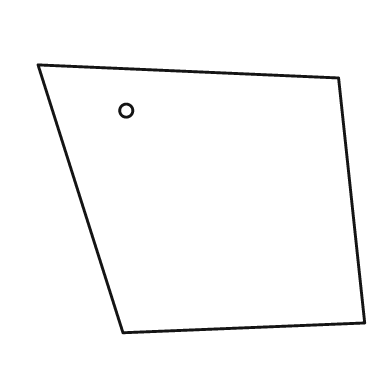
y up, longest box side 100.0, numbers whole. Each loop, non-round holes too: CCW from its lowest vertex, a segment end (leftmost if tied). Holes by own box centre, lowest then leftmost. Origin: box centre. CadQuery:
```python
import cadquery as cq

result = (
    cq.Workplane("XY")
    .moveTo(-24.0, -41.0)
    .lineTo(50.0, -38.0)
    .lineTo(42.0, 37.0)
    .lineTo(-50.0, 41.0)
    .close()
    .moveTo(-23.0, 27.0)
    .circle(2.0)
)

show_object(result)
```